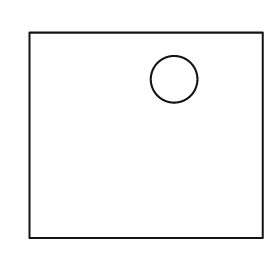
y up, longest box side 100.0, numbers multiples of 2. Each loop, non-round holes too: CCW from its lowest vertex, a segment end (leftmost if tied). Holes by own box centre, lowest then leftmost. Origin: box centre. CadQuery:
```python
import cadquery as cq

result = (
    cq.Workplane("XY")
    .moveTo(-50.0, -44.0)
    .lineTo(50.0, -44.0)
    .lineTo(50.0, 44.0)
    .lineTo(-50.0, 44.0)
    .close()
    .moveTo(12.0, 24.0)
    .circle(10.0)
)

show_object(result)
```